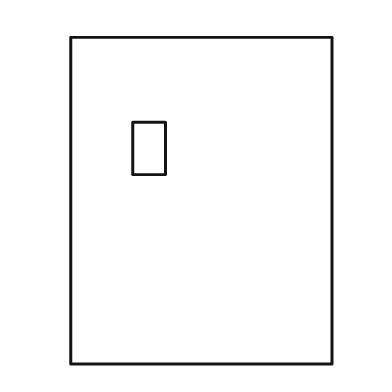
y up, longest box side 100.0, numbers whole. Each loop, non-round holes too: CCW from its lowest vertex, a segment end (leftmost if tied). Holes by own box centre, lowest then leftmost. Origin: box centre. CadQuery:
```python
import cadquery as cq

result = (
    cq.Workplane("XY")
    .moveTo(-40.0, -50.0)
    .lineTo(40.0, -50.0)
    .lineTo(40.0, 50.0)
    .lineTo(-40.0, 50.0)
    .close()
    .moveTo(-21.0, 8.0)
    .lineTo(-11.0, 8.0)
    .lineTo(-11.0, 24.0)
    .lineTo(-21.0, 24.0)
    .close()
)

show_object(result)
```